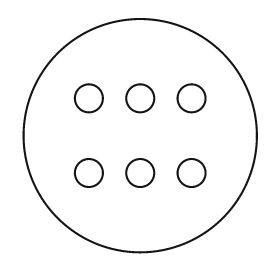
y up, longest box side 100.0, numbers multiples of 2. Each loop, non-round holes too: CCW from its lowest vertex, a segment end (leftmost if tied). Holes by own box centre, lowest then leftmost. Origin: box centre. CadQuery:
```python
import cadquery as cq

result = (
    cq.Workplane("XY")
    .moveTo(0.0, 0.0)
    .circle(50.0)
    .moveTo(-22.0, -16.0)
    .circle(6.0)
    .moveTo(0.0, -16.0)
    .circle(6.0)
    .moveTo(22.0, -16.0)
    .circle(6.0)
    .moveTo(-22.0, 16.0)
    .circle(6.0)
    .moveTo(0.0, 16.0)
    .circle(6.0)
    .moveTo(22.0, 16.0)
    .circle(6.0)
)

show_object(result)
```